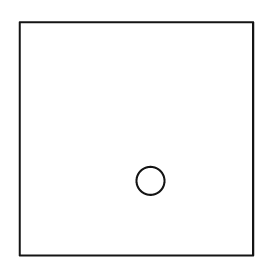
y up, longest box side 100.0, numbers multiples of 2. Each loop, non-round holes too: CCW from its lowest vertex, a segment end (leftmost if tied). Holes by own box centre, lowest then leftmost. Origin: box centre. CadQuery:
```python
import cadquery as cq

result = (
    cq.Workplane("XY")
    .moveTo(-50.0, -50.0)
    .lineTo(50.0, -50.0)
    .lineTo(50.0, 50.0)
    .lineTo(-50.0, 50.0)
    .close()
    .moveTo(6.0, -18.0)
    .circle(6.0)
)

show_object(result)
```